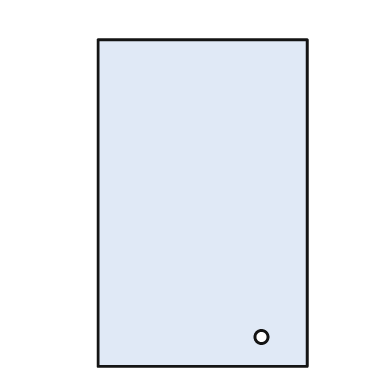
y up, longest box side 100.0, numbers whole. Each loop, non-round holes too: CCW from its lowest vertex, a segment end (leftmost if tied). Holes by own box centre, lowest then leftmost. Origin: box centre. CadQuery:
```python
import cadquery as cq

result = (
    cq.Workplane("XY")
    .moveTo(-32.0, -50.0)
    .lineTo(32.0, -50.0)
    .lineTo(32.0, 50.0)
    .lineTo(-32.0, 50.0)
    .close()
    .moveTo(18.0, -41.0)
    .circle(2.0)
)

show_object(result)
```